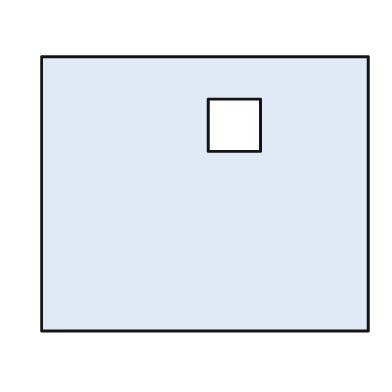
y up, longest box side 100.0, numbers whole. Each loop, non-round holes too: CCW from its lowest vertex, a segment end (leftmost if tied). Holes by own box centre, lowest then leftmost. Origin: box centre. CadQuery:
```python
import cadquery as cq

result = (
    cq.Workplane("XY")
    .moveTo(-50.0, -42.0)
    .lineTo(50.0, -42.0)
    .lineTo(50.0, 42.0)
    .lineTo(-50.0, 42.0)
    .close()
    .moveTo(1.0, 13.0)
    .lineTo(17.0, 13.0)
    .lineTo(17.0, 29.0)
    .lineTo(1.0, 29.0)
    .close()
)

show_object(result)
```